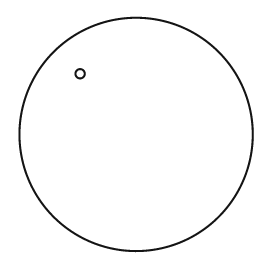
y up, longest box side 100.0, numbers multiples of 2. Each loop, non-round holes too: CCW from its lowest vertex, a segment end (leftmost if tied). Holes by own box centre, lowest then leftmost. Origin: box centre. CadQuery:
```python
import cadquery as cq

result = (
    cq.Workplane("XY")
    .moveTo(0.0, 0.0)
    .circle(50.0)
    .moveTo(-24.0, 26.0)
    .circle(2.0)
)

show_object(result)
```